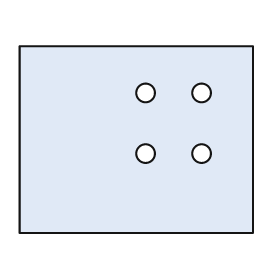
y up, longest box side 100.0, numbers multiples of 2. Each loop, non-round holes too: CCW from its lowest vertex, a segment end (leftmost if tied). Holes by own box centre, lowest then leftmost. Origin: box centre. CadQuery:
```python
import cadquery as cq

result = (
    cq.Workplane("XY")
    .moveTo(-50.0, -40.0)
    .lineTo(50.0, -40.0)
    .lineTo(50.0, 40.0)
    .lineTo(-50.0, 40.0)
    .close()
    .moveTo(4.0, -6.0)
    .circle(4.0)
    .moveTo(28.0, -6.0)
    .circle(4.0)
    .moveTo(4.0, 20.0)
    .circle(4.0)
    .moveTo(28.0, 20.0)
    .circle(4.0)
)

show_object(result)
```